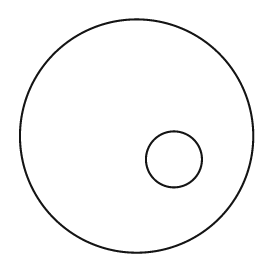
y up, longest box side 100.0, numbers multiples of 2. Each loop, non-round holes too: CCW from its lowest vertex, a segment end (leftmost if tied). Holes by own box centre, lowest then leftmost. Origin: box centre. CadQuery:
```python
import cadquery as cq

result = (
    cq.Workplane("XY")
    .moveTo(0.0, 0.0)
    .circle(50.0)
    .moveTo(16.0, -10.0)
    .circle(12.0)
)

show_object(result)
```